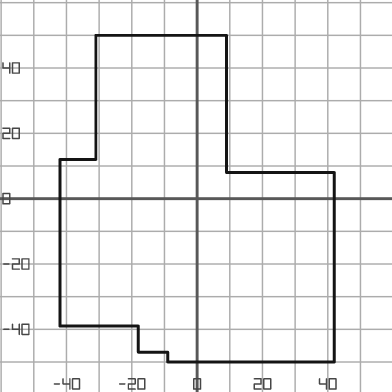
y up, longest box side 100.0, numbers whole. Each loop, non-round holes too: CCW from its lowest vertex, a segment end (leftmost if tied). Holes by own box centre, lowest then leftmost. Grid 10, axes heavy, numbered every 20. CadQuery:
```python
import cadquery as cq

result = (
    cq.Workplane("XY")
    .moveTo(-9.0, -50.0)
    .lineTo(42.0, -50.0)
    .lineTo(42.0, 8.0)
    .lineTo(9.0, 8.0)
    .lineTo(9.0, 50.0)
    .lineTo(-31.0, 50.0)
    .lineTo(-31.0, 12.0)
    .lineTo(-42.0, 12.0)
    .lineTo(-42.0, -39.0)
    .lineTo(-18.0, -39.0)
    .lineTo(-18.0, -47.0)
    .lineTo(-9.0, -47.0)
    .close()
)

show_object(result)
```